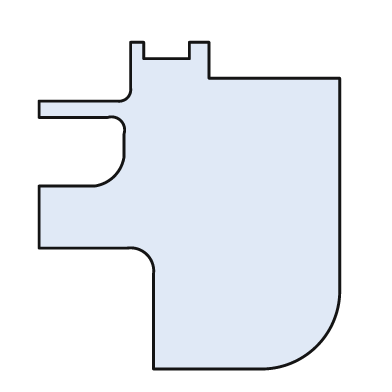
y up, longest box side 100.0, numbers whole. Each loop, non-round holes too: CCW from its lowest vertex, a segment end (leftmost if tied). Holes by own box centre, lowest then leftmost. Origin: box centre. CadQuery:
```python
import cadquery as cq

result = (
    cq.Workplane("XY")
    .moveTo(-11.0, -50.0)
    .lineTo(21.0, -50.0)
    .threePointArc((39.0, -43.0), (46.0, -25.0))
    .lineTo(46.0, 39.0)
    .lineTo(6.0, 39.0)
    .lineTo(6.0, 50.0)
    .lineTo(0.0, 50.0)
    .lineTo(0.0, 45.0)
    .lineTo(-14.0, 45.0)
    .lineTo(-14.0, 50.0)
    .lineTo(-18.0, 50.0)
    .lineTo(-18.0, 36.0)
    .threePointArc((-19.0, 33.0), (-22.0, 32.0))
    .lineTo(-46.0, 32.0)
    .lineTo(-46.0, 27.0)
    .lineTo(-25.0, 27.0)
    .threePointArc((-21.0, 26.0), (-20.0, 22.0))
    .lineTo(-20.0, 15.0)
    .threePointArc((-23.0, 9.0), (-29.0, 6.0))
    .lineTo(-46.0, 6.0)
    .lineTo(-46.0, -13.0)
    .lineTo(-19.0, -13.0)
    .threePointArc((-13.0, -15.0), (-11.0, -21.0))
    .close()
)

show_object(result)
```